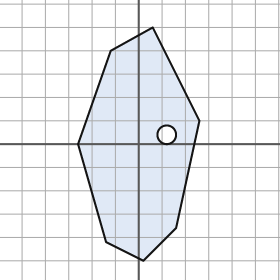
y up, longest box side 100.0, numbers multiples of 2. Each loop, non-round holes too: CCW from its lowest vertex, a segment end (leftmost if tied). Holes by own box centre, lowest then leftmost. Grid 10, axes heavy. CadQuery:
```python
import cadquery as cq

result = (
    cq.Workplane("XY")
    .moveTo(2.0, -50.0)
    .lineTo(16.0, -36.0)
    .lineTo(26.0, 10.0)
    .lineTo(6.0, 50.0)
    .lineTo(-12.0, 40.0)
    .lineTo(-26.0, 0.0)
    .lineTo(-14.0, -42.0)
    .close()
    .moveTo(12.0, 4.0)
    .circle(4.0)
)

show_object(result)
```